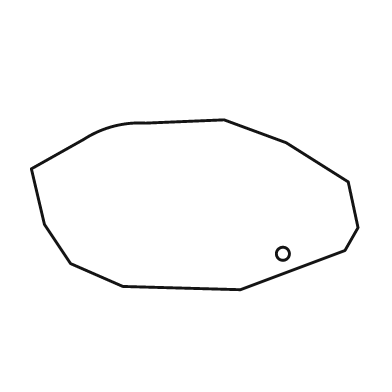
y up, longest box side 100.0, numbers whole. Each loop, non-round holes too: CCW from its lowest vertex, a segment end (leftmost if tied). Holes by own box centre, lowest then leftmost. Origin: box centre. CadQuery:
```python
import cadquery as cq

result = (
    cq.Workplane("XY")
    .moveTo(14.0, -26.0)
    .lineTo(46.0, -14.0)
    .lineTo(50.0, -7.0)
    .lineTo(47.0, 7.0)
    .lineTo(28.0, 19.0)
    .lineTo(9.0, 26.0)
    .lineTo(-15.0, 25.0)
    .threePointArc((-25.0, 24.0), (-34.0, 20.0))
    .lineTo(-50.0, 11.0)
    .lineTo(-46.0, -6.0)
    .lineTo(-38.0, -18.0)
    .lineTo(-22.0, -25.0)
    .close()
    .moveTo(27.0, -15.0)
    .circle(2.0)
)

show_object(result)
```